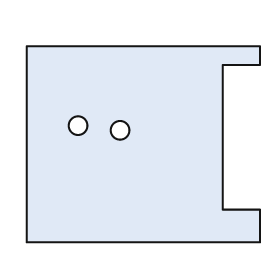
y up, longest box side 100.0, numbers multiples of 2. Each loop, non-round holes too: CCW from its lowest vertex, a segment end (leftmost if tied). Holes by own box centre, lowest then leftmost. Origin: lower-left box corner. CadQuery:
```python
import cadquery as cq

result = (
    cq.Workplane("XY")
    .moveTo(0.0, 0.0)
    .lineTo(100.0, 0.0)
    .lineTo(100.0, 14.0)
    .lineTo(84.0, 14.0)
    .lineTo(84.0, 76.0)
    .lineTo(100.0, 76.0)
    .lineTo(100.0, 84.0)
    .lineTo(0.0, 84.0)
    .close()
    .moveTo(40.0, 48.0)
    .circle(4.0)
    .moveTo(22.0, 50.0)
    .circle(4.0)
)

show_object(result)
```